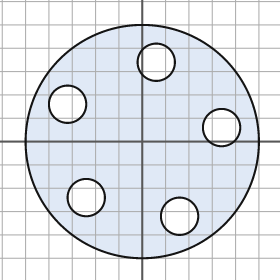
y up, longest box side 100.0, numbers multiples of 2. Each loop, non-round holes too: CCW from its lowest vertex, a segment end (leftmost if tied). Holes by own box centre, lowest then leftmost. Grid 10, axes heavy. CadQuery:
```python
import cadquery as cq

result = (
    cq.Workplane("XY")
    .moveTo(0.0, 0.0)
    .circle(50.0)
    .moveTo(16.0, -32.0)
    .circle(8.0)
    .moveTo(-24.0, -24.0)
    .circle(8.0)
    .moveTo(34.0, 6.0)
    .circle(8.0)
    .moveTo(-32.0, 16.0)
    .circle(8.0)
    .moveTo(6.0, 34.0)
    .circle(8.0)
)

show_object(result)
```